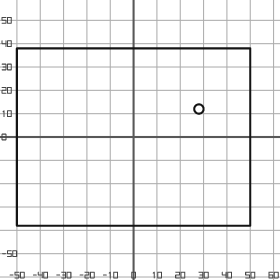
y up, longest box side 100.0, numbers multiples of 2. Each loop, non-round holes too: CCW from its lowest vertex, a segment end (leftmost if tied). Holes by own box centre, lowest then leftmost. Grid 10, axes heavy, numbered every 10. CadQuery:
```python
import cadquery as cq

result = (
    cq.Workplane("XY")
    .moveTo(-50.0, -38.0)
    .lineTo(50.0, -38.0)
    .lineTo(50.0, 38.0)
    .lineTo(-50.0, 38.0)
    .close()
    .moveTo(28.0, 12.0)
    .circle(2.0)
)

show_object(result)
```